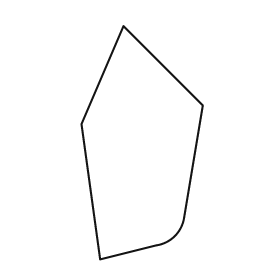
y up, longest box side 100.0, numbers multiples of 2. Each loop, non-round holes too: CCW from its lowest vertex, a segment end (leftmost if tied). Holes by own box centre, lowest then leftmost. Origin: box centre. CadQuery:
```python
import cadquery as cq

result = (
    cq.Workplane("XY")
    .moveTo(-18.0, -50.0)
    .lineTo(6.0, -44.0)
    .threePointArc((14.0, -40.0), (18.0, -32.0))
    .lineTo(26.0, 16.0)
    .lineTo(-8.0, 50.0)
    .lineTo(-26.0, 8.0)
    .close()
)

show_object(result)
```